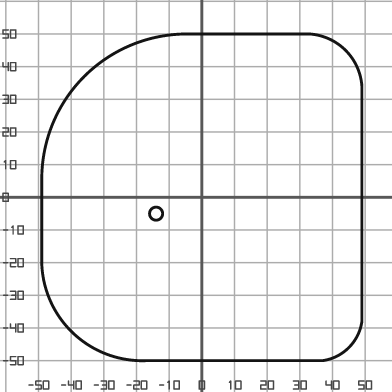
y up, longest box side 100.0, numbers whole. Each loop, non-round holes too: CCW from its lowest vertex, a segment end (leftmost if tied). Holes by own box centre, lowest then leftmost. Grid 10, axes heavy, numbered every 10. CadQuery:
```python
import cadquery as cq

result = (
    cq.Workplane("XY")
    .moveTo(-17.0, -50.0)
    .lineTo(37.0, -50.0)
    .threePointArc((45.0, -46.0), (49.0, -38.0))
    .lineTo(49.0, 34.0)
    .threePointArc((44.0, 45.0), (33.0, 50.0))
    .lineTo(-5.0, 50.0)
    .threePointArc((-36.0, 37.0), (-49.0, 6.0))
    .lineTo(-49.0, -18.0)
    .threePointArc((-40.0, -41.0), (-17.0, -50.0))
    .close()
    .moveTo(-14.0, -5.0)
    .circle(2.0)
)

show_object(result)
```